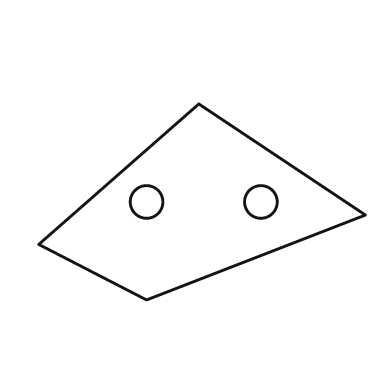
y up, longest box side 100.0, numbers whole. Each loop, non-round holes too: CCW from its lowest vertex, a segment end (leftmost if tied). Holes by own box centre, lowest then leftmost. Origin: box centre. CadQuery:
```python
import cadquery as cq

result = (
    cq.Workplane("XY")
    .moveTo(-17.0, -30.0)
    .lineTo(50.0, -4.0)
    .lineTo(-1.0, 30.0)
    .lineTo(-50.0, -13.0)
    .close()
    .moveTo(-17.0, 0.0)
    .circle(5.0)
    .moveTo(18.0, 0.0)
    .circle(5.0)
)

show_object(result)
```